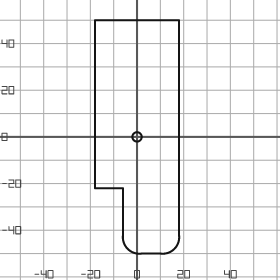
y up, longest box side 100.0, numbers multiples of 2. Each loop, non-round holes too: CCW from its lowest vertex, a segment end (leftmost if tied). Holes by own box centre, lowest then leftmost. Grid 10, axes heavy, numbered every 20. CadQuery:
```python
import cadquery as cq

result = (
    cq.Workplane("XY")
    .moveTo(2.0, -50.0)
    .lineTo(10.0, -50.0)
    .threePointArc((16.0, -48.0), (18.0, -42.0))
    .lineTo(18.0, 50.0)
    .lineTo(-18.0, 50.0)
    .lineTo(-18.0, -22.0)
    .lineTo(-6.0, -22.0)
    .lineTo(-6.0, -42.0)
    .threePointArc((-4.0, -48.0), (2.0, -50.0))
    .close()
    .moveTo(0.0, 0.0)
    .circle(2.0)
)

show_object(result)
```